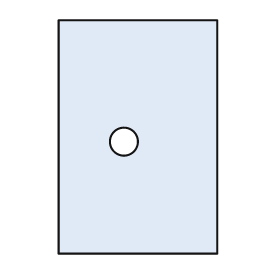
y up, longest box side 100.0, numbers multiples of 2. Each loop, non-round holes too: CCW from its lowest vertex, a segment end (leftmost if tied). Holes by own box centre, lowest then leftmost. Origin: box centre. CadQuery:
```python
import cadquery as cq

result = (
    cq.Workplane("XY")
    .moveTo(-34.0, -50.0)
    .lineTo(34.0, -50.0)
    .lineTo(34.0, 50.0)
    .lineTo(-34.0, 50.0)
    .close()
    .moveTo(-6.0, -2.0)
    .circle(6.0)
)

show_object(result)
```